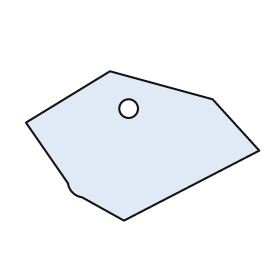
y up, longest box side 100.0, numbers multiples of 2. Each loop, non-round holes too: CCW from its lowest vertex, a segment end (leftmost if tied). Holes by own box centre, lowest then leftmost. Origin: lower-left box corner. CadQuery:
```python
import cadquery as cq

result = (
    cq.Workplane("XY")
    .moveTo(42.0, 0.0)
    .lineTo(100.0, 30.0)
    .lineTo(80.0, 52.0)
    .lineTo(36.0, 64.0)
    .lineTo(0.0, 42.0)
    .lineTo(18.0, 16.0)
    .threePointArc((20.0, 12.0), (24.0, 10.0))
    .close()
    .moveTo(44.0, 48.0)
    .circle(4.0)
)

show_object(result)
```